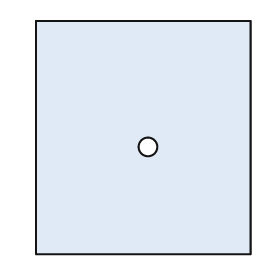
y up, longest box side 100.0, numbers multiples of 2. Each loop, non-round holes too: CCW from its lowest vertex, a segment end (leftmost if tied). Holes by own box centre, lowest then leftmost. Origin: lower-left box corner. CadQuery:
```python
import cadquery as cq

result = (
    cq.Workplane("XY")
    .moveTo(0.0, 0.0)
    .lineTo(92.0, 0.0)
    .lineTo(92.0, 100.0)
    .lineTo(0.0, 100.0)
    .close()
    .moveTo(48.0, 46.0)
    .circle(4.0)
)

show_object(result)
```